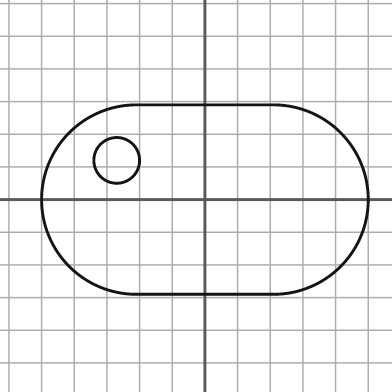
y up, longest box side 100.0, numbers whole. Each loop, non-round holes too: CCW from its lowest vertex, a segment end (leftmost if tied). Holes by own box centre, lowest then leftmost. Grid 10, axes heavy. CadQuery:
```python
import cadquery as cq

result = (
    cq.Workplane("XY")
    .moveTo(-21.0, -29.0)
    .lineTo(21.0, -29.0)
    .threePointArc((50.0, 0.0), (21.0, 29.0))
    .lineTo(-21.0, 29.0)
    .threePointArc((-50.0, 0.0), (-21.0, -29.0))
    .close()
    .moveTo(-27.0, 12.0)
    .circle(7.0)
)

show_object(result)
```